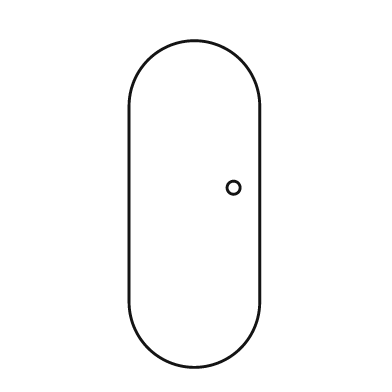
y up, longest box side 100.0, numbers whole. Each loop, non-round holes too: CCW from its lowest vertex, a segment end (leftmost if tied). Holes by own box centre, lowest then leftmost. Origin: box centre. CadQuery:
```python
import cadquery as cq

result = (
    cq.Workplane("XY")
    .moveTo(-20.0, -30.0)
    .threePointArc((0.0, -50.0), (20.0, -30.0))
    .lineTo(20.0, 30.0)
    .threePointArc((0.0, 50.0), (-20.0, 30.0))
    .close()
    .moveTo(12.0, 5.0)
    .circle(2.0)
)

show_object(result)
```